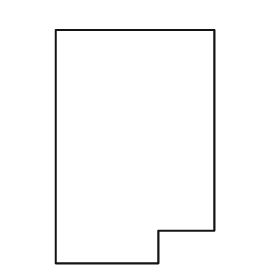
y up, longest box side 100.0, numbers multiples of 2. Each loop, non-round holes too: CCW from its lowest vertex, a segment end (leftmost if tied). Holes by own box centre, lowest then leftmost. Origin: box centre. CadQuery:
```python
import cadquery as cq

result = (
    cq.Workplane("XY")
    .moveTo(-34.0, -50.0)
    .lineTo(10.0, -50.0)
    .lineTo(10.0, -36.0)
    .lineTo(34.0, -36.0)
    .lineTo(34.0, 50.0)
    .lineTo(-34.0, 50.0)
    .close()
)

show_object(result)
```